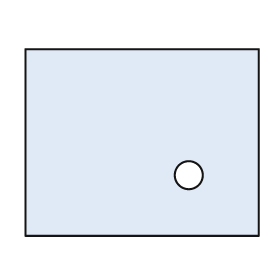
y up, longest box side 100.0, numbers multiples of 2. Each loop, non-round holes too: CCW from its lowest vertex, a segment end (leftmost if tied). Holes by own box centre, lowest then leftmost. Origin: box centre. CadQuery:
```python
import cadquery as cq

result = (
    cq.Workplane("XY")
    .moveTo(-50.0, -40.0)
    .lineTo(50.0, -40.0)
    .lineTo(50.0, 40.0)
    .lineTo(-50.0, 40.0)
    .close()
    .moveTo(20.0, -14.0)
    .circle(6.0)
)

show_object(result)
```